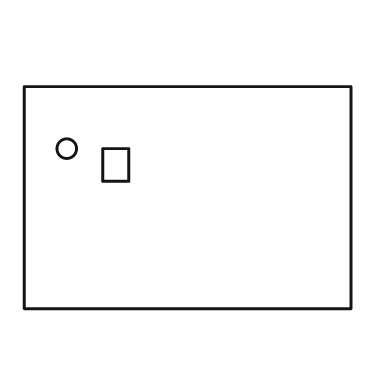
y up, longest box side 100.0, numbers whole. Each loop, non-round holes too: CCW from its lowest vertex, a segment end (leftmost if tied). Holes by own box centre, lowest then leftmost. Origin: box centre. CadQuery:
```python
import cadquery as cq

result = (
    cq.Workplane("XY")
    .moveTo(-50.0, -34.0)
    .lineTo(50.0, -34.0)
    .lineTo(50.0, 34.0)
    .lineTo(-50.0, 34.0)
    .close()
    .moveTo(-26.0, 5.0)
    .lineTo(-18.0, 5.0)
    .lineTo(-18.0, 15.0)
    .lineTo(-26.0, 15.0)
    .close()
    .moveTo(-37.0, 15.0)
    .circle(3.0)
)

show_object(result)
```